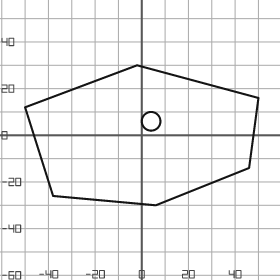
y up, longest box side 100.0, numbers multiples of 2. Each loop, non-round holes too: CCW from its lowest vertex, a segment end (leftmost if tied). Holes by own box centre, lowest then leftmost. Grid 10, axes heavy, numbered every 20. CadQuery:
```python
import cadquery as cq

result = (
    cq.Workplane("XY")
    .moveTo(6.0, -30.0)
    .lineTo(46.0, -14.0)
    .lineTo(50.0, 16.0)
    .lineTo(-2.0, 30.0)
    .lineTo(-50.0, 12.0)
    .lineTo(-38.0, -26.0)
    .close()
    .moveTo(4.0, 6.0)
    .circle(4.0)
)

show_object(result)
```